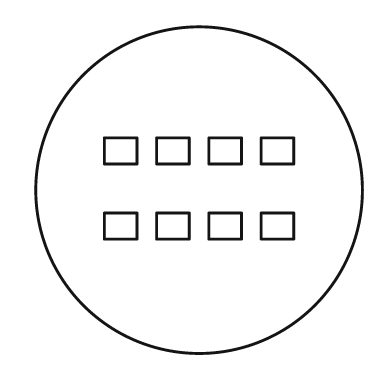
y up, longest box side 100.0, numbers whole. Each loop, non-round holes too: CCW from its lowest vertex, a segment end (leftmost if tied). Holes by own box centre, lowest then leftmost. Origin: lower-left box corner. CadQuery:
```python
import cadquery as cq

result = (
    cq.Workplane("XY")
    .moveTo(50.0, 50.0)
    .circle(50.0)
    .moveTo(21.0, 35.0)
    .lineTo(31.0, 35.0)
    .lineTo(31.0, 43.0)
    .lineTo(21.0, 43.0)
    .close()
    .moveTo(37.0, 35.0)
    .lineTo(47.0, 35.0)
    .lineTo(47.0, 43.0)
    .lineTo(37.0, 43.0)
    .close()
    .moveTo(53.0, 35.0)
    .lineTo(63.0, 35.0)
    .lineTo(63.0, 43.0)
    .lineTo(53.0, 43.0)
    .close()
    .moveTo(69.0, 35.0)
    .lineTo(79.0, 35.0)
    .lineTo(79.0, 43.0)
    .lineTo(69.0, 43.0)
    .close()
    .moveTo(21.0, 58.0)
    .lineTo(31.0, 58.0)
    .lineTo(31.0, 66.0)
    .lineTo(21.0, 66.0)
    .close()
    .moveTo(37.0, 58.0)
    .lineTo(47.0, 58.0)
    .lineTo(47.0, 66.0)
    .lineTo(37.0, 66.0)
    .close()
    .moveTo(53.0, 58.0)
    .lineTo(63.0, 58.0)
    .lineTo(63.0, 66.0)
    .lineTo(53.0, 66.0)
    .close()
    .moveTo(69.0, 58.0)
    .lineTo(79.0, 58.0)
    .lineTo(79.0, 66.0)
    .lineTo(69.0, 66.0)
    .close()
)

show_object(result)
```